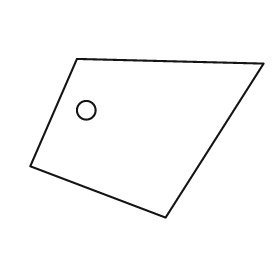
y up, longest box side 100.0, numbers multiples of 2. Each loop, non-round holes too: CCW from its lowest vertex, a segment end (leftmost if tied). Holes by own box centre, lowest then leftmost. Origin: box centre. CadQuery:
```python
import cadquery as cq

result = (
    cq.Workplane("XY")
    .moveTo(8.0, -34.0)
    .lineTo(50.0, 32.0)
    .lineTo(-30.0, 34.0)
    .lineTo(-50.0, -12.0)
    .close()
    .moveTo(-26.0, 12.0)
    .circle(4.0)
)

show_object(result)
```